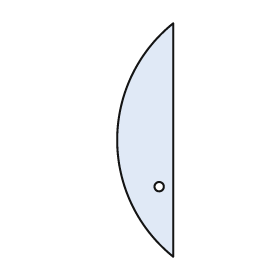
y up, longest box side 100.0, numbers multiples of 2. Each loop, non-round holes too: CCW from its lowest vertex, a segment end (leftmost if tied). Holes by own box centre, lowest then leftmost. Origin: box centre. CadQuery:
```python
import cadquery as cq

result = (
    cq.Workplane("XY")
    .moveTo(12.0, -50.0)
    .lineTo(12.0, 50.0)
    .threePointArc((-12.0, 0.0), (12.0, -50.0))
    .close()
    .moveTo(6.0, -20.0)
    .circle(2.0)
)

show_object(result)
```